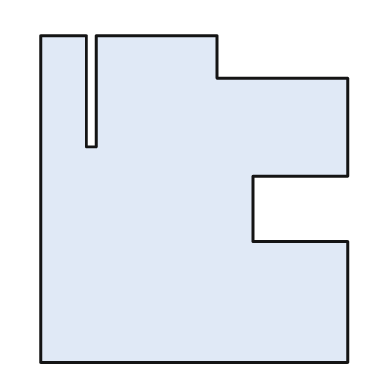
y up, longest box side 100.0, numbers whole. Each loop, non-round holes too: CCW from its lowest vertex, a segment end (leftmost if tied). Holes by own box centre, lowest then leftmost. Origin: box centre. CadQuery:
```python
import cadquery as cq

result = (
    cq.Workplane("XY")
    .moveTo(-47.0, -50.0)
    .lineTo(47.0, -50.0)
    .lineTo(47.0, -13.0)
    .lineTo(18.0, -13.0)
    .lineTo(18.0, 7.0)
    .lineTo(47.0, 7.0)
    .lineTo(47.0, 37.0)
    .lineTo(7.0, 37.0)
    .lineTo(7.0, 50.0)
    .lineTo(-30.0, 50.0)
    .lineTo(-30.0, 16.0)
    .lineTo(-33.0, 16.0)
    .lineTo(-33.0, 50.0)
    .lineTo(-47.0, 50.0)
    .close()
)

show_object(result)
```